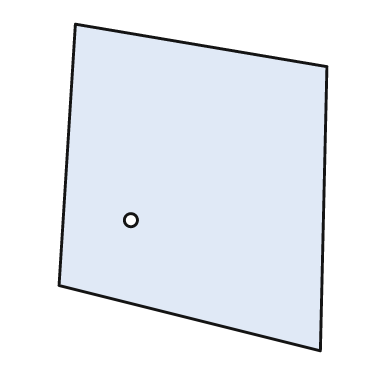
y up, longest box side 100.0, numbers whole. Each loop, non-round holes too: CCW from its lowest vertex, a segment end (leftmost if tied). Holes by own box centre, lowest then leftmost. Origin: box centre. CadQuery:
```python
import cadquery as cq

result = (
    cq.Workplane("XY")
    .moveTo(39.0, -50.0)
    .lineTo(41.0, 37.0)
    .lineTo(-36.0, 50.0)
    .lineTo(-41.0, -30.0)
    .close()
    .moveTo(-19.0, -10.0)
    .circle(2.0)
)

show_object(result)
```